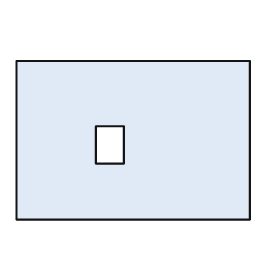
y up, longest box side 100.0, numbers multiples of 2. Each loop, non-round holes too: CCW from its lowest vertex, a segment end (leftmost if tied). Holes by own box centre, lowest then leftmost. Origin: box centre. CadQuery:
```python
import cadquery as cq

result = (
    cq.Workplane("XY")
    .moveTo(-50.0, -34.0)
    .lineTo(50.0, -34.0)
    .lineTo(50.0, 34.0)
    .lineTo(-50.0, 34.0)
    .close()
    .moveTo(-16.0, -10.0)
    .lineTo(-4.0, -10.0)
    .lineTo(-4.0, 6.0)
    .lineTo(-16.0, 6.0)
    .close()
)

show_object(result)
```